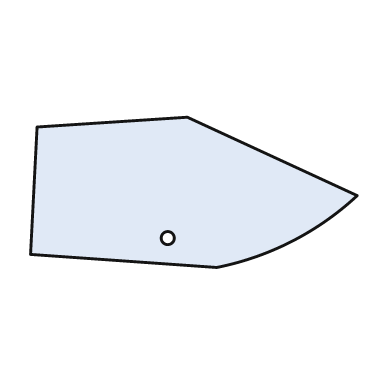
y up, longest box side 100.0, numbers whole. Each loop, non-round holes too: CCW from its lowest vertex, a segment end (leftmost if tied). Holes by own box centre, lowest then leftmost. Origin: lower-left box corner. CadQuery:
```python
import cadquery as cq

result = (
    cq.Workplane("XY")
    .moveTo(57.0, 0.0)
    .threePointArc((80.0, 8.0), (100.0, 22.0))
    .lineTo(48.0, 46.0)
    .lineTo(2.0, 43.0)
    .lineTo(0.0, 4.0)
    .close()
    .moveTo(42.0, 9.0)
    .circle(2.0)
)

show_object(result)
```